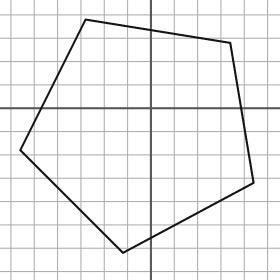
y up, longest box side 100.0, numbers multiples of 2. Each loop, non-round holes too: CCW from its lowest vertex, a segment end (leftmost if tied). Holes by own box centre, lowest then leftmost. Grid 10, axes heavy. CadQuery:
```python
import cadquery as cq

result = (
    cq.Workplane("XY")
    .moveTo(-12.0, -62.0)
    .lineTo(44.0, -32.0)
    .lineTo(34.0, 28.0)
    .lineTo(-28.0, 38.0)
    .lineTo(-56.0, -18.0)
    .close()
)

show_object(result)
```